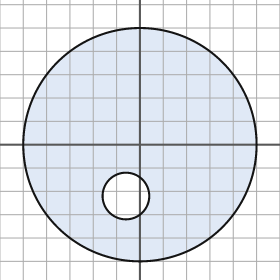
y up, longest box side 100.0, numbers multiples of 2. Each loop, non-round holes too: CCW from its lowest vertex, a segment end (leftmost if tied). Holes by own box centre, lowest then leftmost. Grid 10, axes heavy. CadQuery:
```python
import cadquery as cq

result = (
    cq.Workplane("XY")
    .moveTo(0.0, 0.0)
    .circle(50.0)
    .moveTo(-6.0, -22.0)
    .circle(10.0)
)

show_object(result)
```